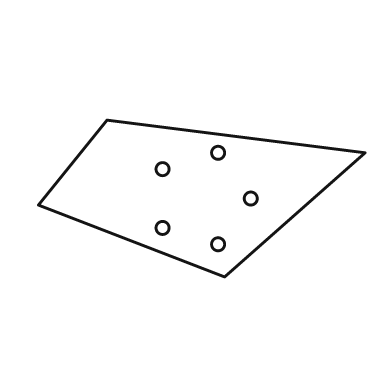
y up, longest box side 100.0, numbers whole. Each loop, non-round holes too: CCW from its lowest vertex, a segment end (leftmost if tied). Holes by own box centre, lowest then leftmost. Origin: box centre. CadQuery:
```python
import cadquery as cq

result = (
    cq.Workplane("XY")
    .moveTo(7.0, -24.0)
    .lineTo(50.0, 14.0)
    .lineTo(-29.0, 24.0)
    .lineTo(-50.0, -2.0)
    .close()
    .moveTo(5.0, -14.0)
    .circle(2.0)
    .moveTo(-12.0, -9.0)
    .circle(2.0)
    .moveTo(15.0, 0.0)
    .circle(2.0)
    .moveTo(-12.0, 9.0)
    .circle(2.0)
    .moveTo(5.0, 14.0)
    .circle(2.0)
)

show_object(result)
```